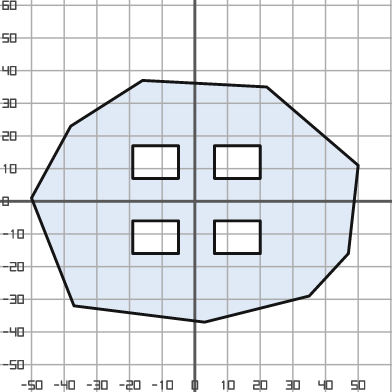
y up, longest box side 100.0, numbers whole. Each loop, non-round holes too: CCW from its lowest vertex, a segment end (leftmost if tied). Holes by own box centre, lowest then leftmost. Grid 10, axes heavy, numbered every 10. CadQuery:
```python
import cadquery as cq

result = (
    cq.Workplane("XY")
    .moveTo(3.0, -37.0)
    .lineTo(35.0, -29.0)
    .lineTo(47.0, -16.0)
    .lineTo(50.0, 11.0)
    .lineTo(22.0, 35.0)
    .lineTo(-16.0, 37.0)
    .lineTo(-38.0, 23.0)
    .lineTo(-50.0, 1.0)
    .lineTo(-37.0, -32.0)
    .close()
    .moveTo(-19.0, -16.0)
    .lineTo(-5.0, -16.0)
    .lineTo(-5.0, -6.0)
    .lineTo(-19.0, -6.0)
    .close()
    .moveTo(6.0, -16.0)
    .lineTo(20.0, -16.0)
    .lineTo(20.0, -6.0)
    .lineTo(6.0, -6.0)
    .close()
    .moveTo(-19.0, 7.0)
    .lineTo(-5.0, 7.0)
    .lineTo(-5.0, 17.0)
    .lineTo(-19.0, 17.0)
    .close()
    .moveTo(6.0, 7.0)
    .lineTo(20.0, 7.0)
    .lineTo(20.0, 17.0)
    .lineTo(6.0, 17.0)
    .close()
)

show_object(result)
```